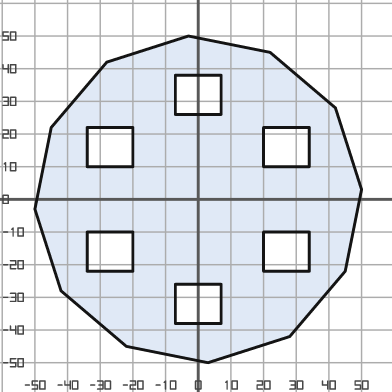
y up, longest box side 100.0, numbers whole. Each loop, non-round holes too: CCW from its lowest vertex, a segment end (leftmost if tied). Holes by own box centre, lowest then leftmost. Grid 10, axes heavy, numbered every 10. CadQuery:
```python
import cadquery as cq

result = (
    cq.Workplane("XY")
    .moveTo(3.0, -50.0)
    .lineTo(28.0, -42.0)
    .lineTo(45.0, -22.0)
    .lineTo(50.0, 3.0)
    .lineTo(42.0, 28.0)
    .lineTo(22.0, 45.0)
    .lineTo(-3.0, 50.0)
    .lineTo(-28.0, 42.0)
    .lineTo(-45.0, 22.0)
    .lineTo(-50.0, -3.0)
    .lineTo(-42.0, -28.0)
    .lineTo(-22.0, -45.0)
    .close()
    .moveTo(-7.0, -38.0)
    .lineTo(7.0, -38.0)
    .lineTo(7.0, -26.0)
    .lineTo(-7.0, -26.0)
    .close()
    .moveTo(-34.0, -22.0)
    .lineTo(-20.0, -22.0)
    .lineTo(-20.0, -10.0)
    .lineTo(-34.0, -10.0)
    .close()
    .moveTo(20.0, -22.0)
    .lineTo(34.0, -22.0)
    .lineTo(34.0, -10.0)
    .lineTo(20.0, -10.0)
    .close()
    .moveTo(-34.0, 10.0)
    .lineTo(-20.0, 10.0)
    .lineTo(-20.0, 22.0)
    .lineTo(-34.0, 22.0)
    .close()
    .moveTo(20.0, 10.0)
    .lineTo(34.0, 10.0)
    .lineTo(34.0, 22.0)
    .lineTo(20.0, 22.0)
    .close()
    .moveTo(-7.0, 26.0)
    .lineTo(7.0, 26.0)
    .lineTo(7.0, 38.0)
    .lineTo(-7.0, 38.0)
    .close()
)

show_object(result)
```